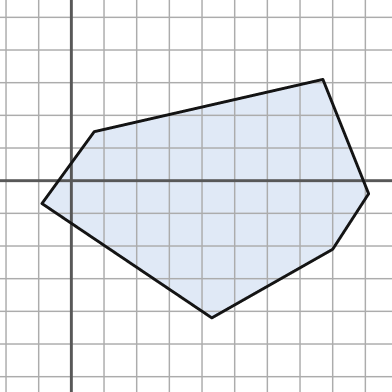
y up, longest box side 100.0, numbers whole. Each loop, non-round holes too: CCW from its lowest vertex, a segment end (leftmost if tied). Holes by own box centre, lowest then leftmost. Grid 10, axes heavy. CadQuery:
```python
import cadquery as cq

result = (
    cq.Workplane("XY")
    .moveTo(43.0, -42.0)
    .lineTo(80.0, -21.0)
    .lineTo(91.0, -4.0)
    .lineTo(77.0, 31.0)
    .lineTo(7.0, 15.0)
    .lineTo(-9.0, -7.0)
    .close()
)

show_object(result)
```